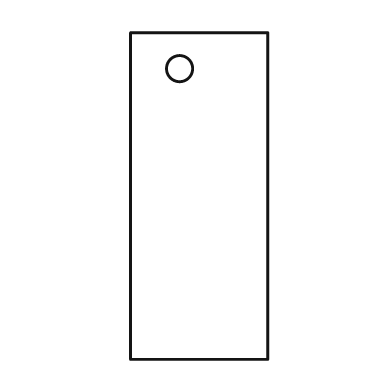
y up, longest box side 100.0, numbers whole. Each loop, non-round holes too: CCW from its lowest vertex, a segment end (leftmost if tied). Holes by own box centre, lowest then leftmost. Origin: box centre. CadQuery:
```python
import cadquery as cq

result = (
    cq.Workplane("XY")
    .moveTo(-21.0, -50.0)
    .lineTo(21.0, -50.0)
    .lineTo(21.0, 50.0)
    .lineTo(-21.0, 50.0)
    .close()
    .moveTo(-6.0, 39.0)
    .circle(4.0)
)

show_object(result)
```